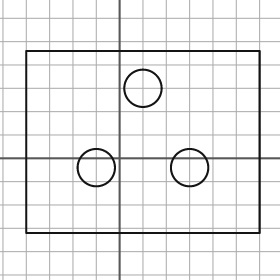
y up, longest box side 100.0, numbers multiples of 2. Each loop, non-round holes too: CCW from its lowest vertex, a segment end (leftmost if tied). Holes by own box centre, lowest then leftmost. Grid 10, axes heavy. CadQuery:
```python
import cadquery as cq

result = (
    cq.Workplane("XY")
    .moveTo(-40.0, -32.0)
    .lineTo(60.0, -32.0)
    .lineTo(60.0, 46.0)
    .lineTo(-40.0, 46.0)
    .close()
    .moveTo(-10.0, -4.0)
    .circle(8.0)
    .moveTo(30.0, -4.0)
    .circle(8.0)
    .moveTo(10.0, 30.0)
    .circle(8.0)
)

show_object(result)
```